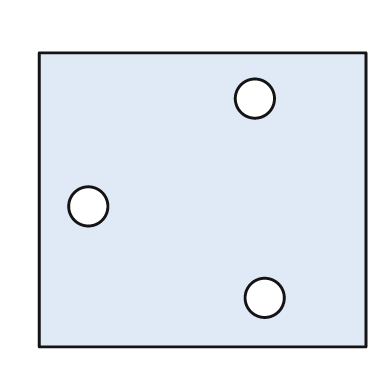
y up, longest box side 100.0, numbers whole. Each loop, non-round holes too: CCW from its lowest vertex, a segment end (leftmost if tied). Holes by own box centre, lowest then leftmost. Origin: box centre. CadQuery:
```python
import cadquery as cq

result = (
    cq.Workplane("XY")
    .moveTo(-50.0, -45.0)
    .lineTo(50.0, -45.0)
    .lineTo(50.0, 45.0)
    .lineTo(-50.0, 45.0)
    .close()
    .moveTo(19.0, -30.0)
    .circle(6.0)
    .moveTo(-35.0, -2.0)
    .circle(6.0)
    .moveTo(16.0, 31.0)
    .circle(6.0)
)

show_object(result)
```